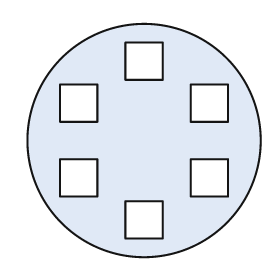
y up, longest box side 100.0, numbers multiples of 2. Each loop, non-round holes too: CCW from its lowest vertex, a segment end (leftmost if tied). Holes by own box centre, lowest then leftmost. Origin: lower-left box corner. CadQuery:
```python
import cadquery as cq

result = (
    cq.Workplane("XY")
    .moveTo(50.0, 50.0)
    .circle(50.0)
    .moveTo(42.0, 8.0)
    .lineTo(58.0, 8.0)
    .lineTo(58.0, 24.0)
    .lineTo(42.0, 24.0)
    .close()
    .moveTo(14.0, 26.0)
    .lineTo(30.0, 26.0)
    .lineTo(30.0, 42.0)
    .lineTo(14.0, 42.0)
    .close()
    .moveTo(70.0, 26.0)
    .lineTo(86.0, 26.0)
    .lineTo(86.0, 42.0)
    .lineTo(70.0, 42.0)
    .close()
    .moveTo(14.0, 58.0)
    .lineTo(30.0, 58.0)
    .lineTo(30.0, 74.0)
    .lineTo(14.0, 74.0)
    .close()
    .moveTo(70.0, 58.0)
    .lineTo(86.0, 58.0)
    .lineTo(86.0, 74.0)
    .lineTo(70.0, 74.0)
    .close()
    .moveTo(42.0, 76.0)
    .lineTo(58.0, 76.0)
    .lineTo(58.0, 92.0)
    .lineTo(42.0, 92.0)
    .close()
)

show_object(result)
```